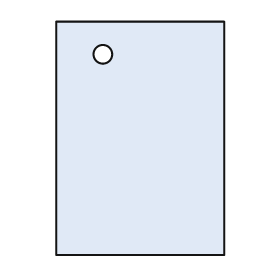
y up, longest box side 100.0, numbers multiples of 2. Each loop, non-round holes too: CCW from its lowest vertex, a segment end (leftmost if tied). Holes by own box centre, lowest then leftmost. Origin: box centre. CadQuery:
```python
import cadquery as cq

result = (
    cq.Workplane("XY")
    .moveTo(-36.0, -50.0)
    .lineTo(36.0, -50.0)
    .lineTo(36.0, 50.0)
    .lineTo(-36.0, 50.0)
    .close()
    .moveTo(-16.0, 36.0)
    .circle(4.0)
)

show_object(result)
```